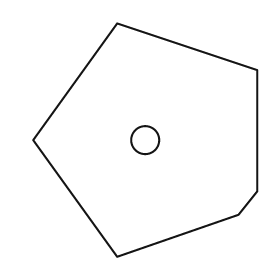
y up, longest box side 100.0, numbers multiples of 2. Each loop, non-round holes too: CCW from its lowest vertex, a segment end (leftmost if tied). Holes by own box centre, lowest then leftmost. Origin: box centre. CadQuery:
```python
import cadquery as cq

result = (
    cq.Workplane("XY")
    .moveTo(-12.0, -50.0)
    .lineTo(40.0, -32.0)
    .lineTo(48.0, -22.0)
    .lineTo(48.0, 30.0)
    .lineTo(-12.0, 50.0)
    .lineTo(-48.0, 0.0)
    .close()
    .moveTo(0.0, 0.0)
    .circle(6.0)
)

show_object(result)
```